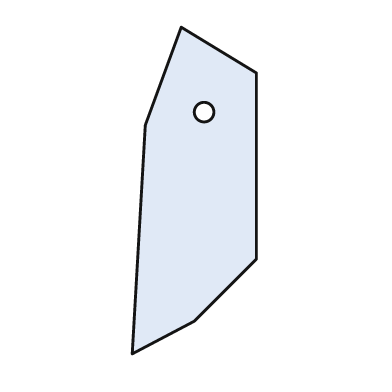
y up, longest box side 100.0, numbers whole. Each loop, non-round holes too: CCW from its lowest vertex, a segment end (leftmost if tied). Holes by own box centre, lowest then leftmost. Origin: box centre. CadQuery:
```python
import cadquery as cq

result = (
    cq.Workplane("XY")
    .moveTo(-19.0, -50.0)
    .lineTo(0.0, -40.0)
    .lineTo(19.0, -21.0)
    .lineTo(19.0, 36.0)
    .lineTo(-4.0, 50.0)
    .lineTo(-15.0, 20.0)
    .close()
    .moveTo(3.0, 24.0)
    .circle(3.0)
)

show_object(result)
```